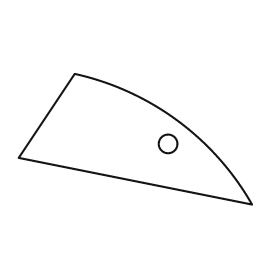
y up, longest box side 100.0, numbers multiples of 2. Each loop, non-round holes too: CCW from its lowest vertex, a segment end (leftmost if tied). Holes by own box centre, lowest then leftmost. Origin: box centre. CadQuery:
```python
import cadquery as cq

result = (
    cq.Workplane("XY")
    .moveTo(50.0, -28.0)
    .threePointArc((18.0, 8.0), (-26.0, 28.0))
    .lineTo(-50.0, -8.0)
    .close()
    .moveTo(14.0, -2.0)
    .circle(4.0)
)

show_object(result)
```